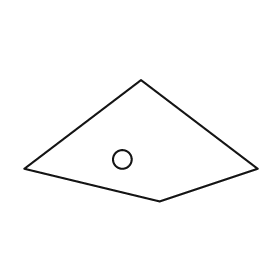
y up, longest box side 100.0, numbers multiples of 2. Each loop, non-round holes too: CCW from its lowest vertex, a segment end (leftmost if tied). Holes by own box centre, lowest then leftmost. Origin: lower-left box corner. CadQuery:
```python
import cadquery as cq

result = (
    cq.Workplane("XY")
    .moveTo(58.0, 0.0)
    .lineTo(100.0, 14.0)
    .lineTo(50.0, 52.0)
    .lineTo(0.0, 14.0)
    .close()
    .moveTo(42.0, 18.0)
    .circle(4.0)
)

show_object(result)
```